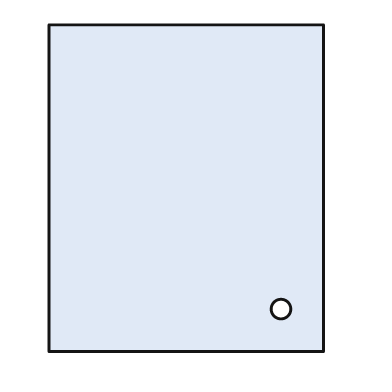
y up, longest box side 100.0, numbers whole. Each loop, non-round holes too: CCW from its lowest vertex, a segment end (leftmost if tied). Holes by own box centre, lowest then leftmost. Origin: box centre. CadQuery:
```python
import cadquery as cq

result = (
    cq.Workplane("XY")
    .moveTo(-42.0, -50.0)
    .lineTo(42.0, -50.0)
    .lineTo(42.0, 50.0)
    .lineTo(-42.0, 50.0)
    .close()
    .moveTo(29.0, -37.0)
    .circle(3.0)
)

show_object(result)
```